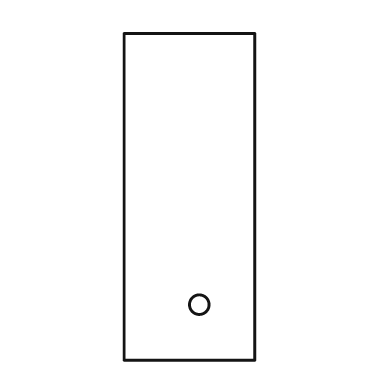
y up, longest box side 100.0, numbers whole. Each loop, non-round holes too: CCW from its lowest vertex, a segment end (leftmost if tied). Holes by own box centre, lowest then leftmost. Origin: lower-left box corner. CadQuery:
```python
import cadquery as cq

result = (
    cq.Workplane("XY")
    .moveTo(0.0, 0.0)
    .lineTo(40.0, 0.0)
    .lineTo(40.0, 100.0)
    .lineTo(0.0, 100.0)
    .close()
    .moveTo(23.0, 17.0)
    .circle(3.0)
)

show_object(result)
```